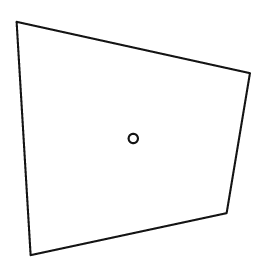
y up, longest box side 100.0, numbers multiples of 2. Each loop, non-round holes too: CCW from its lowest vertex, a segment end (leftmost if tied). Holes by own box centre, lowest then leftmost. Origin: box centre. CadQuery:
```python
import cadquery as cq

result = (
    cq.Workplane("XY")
    .moveTo(-44.0, -50.0)
    .lineTo(40.0, -32.0)
    .lineTo(50.0, 28.0)
    .lineTo(-50.0, 50.0)
    .close()
    .moveTo(0.0, 0.0)
    .circle(2.0)
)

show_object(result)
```